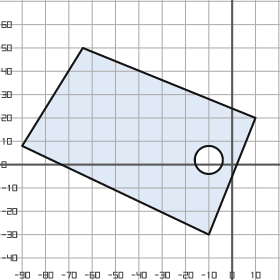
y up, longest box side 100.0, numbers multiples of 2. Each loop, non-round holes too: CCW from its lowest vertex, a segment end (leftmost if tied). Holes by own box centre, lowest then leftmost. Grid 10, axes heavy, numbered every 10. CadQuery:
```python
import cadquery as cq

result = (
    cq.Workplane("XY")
    .moveTo(-10.0, -30.0)
    .lineTo(10.0, 20.0)
    .lineTo(-64.0, 50.0)
    .lineTo(-90.0, 8.0)
    .close()
    .moveTo(-10.0, 2.0)
    .circle(6.0)
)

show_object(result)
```